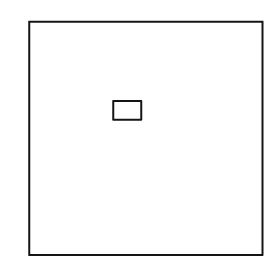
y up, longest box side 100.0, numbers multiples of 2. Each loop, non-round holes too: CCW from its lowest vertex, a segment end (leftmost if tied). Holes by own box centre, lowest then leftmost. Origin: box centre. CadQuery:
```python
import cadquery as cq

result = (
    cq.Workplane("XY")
    .moveTo(-50.0, -50.0)
    .lineTo(50.0, -50.0)
    .lineTo(50.0, 50.0)
    .lineTo(-50.0, 50.0)
    .close()
    .moveTo(-14.0, 8.0)
    .lineTo(-2.0, 8.0)
    .lineTo(-2.0, 16.0)
    .lineTo(-14.0, 16.0)
    .close()
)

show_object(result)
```